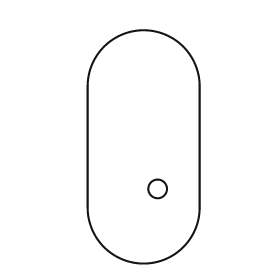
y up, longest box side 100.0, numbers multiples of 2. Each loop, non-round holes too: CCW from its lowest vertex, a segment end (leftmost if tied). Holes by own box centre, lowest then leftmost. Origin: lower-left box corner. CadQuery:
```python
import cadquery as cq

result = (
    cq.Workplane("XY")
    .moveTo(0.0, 24.0)
    .threePointArc((24.0, 0.0), (48.0, 24.0))
    .lineTo(48.0, 76.0)
    .threePointArc((24.0, 100.0), (0.0, 76.0))
    .close()
    .moveTo(30.0, 32.0)
    .circle(4.0)
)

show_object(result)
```